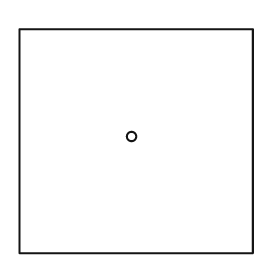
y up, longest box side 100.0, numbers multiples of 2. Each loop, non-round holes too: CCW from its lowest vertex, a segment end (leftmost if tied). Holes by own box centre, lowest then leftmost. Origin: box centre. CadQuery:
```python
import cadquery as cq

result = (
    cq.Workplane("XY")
    .moveTo(-50.0, -48.0)
    .lineTo(50.0, -48.0)
    .lineTo(50.0, 48.0)
    .lineTo(-50.0, 48.0)
    .close()
    .moveTo(-2.0, 2.0)
    .circle(2.0)
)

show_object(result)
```